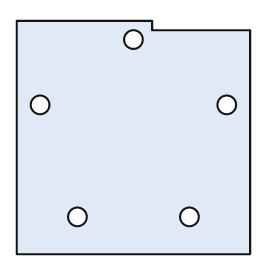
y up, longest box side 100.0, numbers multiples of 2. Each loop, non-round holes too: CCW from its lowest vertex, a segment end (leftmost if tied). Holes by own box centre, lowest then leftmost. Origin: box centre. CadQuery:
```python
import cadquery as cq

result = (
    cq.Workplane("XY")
    .moveTo(-50.0, -50.0)
    .lineTo(50.0, -50.0)
    .lineTo(50.0, 46.0)
    .lineTo(8.0, 46.0)
    .lineTo(8.0, 50.0)
    .lineTo(-50.0, 50.0)
    .close()
    .moveTo(-24.0, -34.0)
    .circle(4.0)
    .moveTo(24.0, -34.0)
    .circle(4.0)
    .moveTo(-40.0, 14.0)
    .circle(4.0)
    .moveTo(40.0, 14.0)
    .circle(4.0)
    .moveTo(0.0, 42.0)
    .circle(4.0)
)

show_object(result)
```